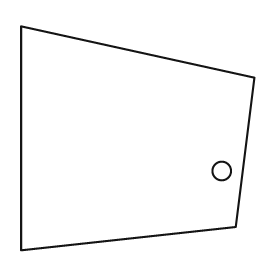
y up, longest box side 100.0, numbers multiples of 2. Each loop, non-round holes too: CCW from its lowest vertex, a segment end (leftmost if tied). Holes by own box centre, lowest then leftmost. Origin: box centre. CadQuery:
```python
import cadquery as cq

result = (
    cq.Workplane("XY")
    .moveTo(-50.0, -48.0)
    .lineTo(42.0, -38.0)
    .lineTo(50.0, 26.0)
    .lineTo(-50.0, 48.0)
    .close()
    .moveTo(36.0, -14.0)
    .circle(4.0)
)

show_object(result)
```